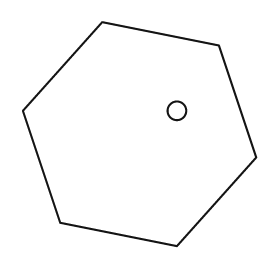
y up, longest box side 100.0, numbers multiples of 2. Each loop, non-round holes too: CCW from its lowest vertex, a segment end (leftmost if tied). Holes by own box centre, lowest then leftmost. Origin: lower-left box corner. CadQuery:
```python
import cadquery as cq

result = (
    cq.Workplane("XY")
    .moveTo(66.0, 0.0)
    .lineTo(100.0, 38.0)
    .lineTo(84.0, 86.0)
    .lineTo(34.0, 96.0)
    .lineTo(0.0, 58.0)
    .lineTo(16.0, 10.0)
    .close()
    .moveTo(66.0, 58.0)
    .circle(4.0)
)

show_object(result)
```